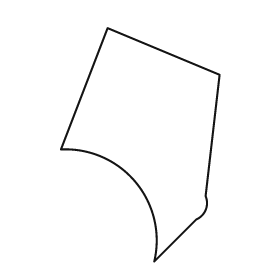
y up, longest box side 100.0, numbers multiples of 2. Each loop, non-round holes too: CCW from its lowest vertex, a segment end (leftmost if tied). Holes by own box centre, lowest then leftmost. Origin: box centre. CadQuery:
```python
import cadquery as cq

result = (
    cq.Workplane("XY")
    .moveTo(6.0, -50.0)
    .lineTo(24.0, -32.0)
    .threePointArc((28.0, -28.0), (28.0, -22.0))
    .lineTo(34.0, 30.0)
    .lineTo(-14.0, 50.0)
    .lineTo(-34.0, -2.0)
    .threePointArc((-2.0, -16.0), (6.0, -50.0))
    .close()
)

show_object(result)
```